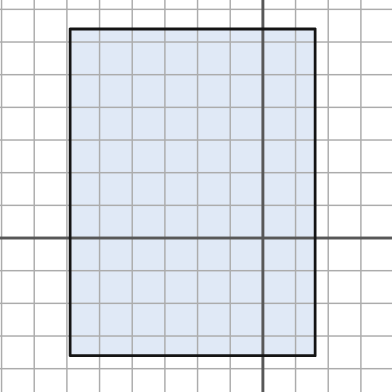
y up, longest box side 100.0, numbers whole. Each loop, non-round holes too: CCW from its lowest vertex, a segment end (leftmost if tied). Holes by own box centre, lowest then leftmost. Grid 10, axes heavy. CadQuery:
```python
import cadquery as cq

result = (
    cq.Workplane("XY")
    .moveTo(-59.0, -36.0)
    .lineTo(16.0, -36.0)
    .lineTo(16.0, 64.0)
    .lineTo(-59.0, 64.0)
    .close()
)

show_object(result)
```